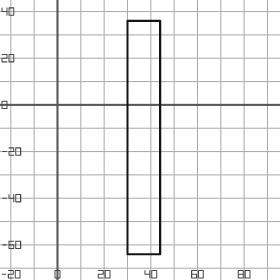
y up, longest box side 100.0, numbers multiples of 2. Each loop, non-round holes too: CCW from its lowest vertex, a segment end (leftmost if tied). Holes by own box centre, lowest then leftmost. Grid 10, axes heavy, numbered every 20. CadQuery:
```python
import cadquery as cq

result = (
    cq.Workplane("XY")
    .moveTo(30.0, -64.0)
    .lineTo(44.0, -64.0)
    .lineTo(44.0, 36.0)
    .lineTo(30.0, 36.0)
    .close()
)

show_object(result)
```